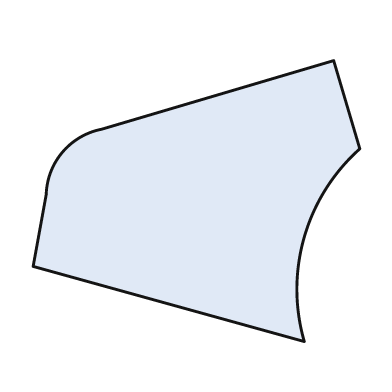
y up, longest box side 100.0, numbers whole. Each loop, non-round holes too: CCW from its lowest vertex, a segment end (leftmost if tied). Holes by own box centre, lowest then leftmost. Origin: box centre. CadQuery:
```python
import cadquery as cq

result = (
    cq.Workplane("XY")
    .moveTo(33.0, -43.0)
    .threePointArc((33.0, -11.0), (50.0, 16.0))
    .lineTo(42.0, 43.0)
    .lineTo(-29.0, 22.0)
    .threePointArc((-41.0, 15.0), (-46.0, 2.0))
    .lineTo(-50.0, -20.0)
    .close()
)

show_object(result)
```